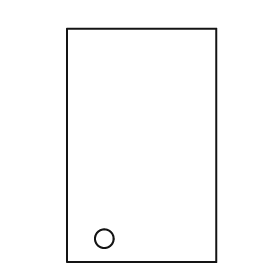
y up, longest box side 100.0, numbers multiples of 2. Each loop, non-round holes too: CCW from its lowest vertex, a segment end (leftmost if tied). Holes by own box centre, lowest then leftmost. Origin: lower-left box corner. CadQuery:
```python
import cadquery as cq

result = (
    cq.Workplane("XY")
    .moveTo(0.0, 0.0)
    .lineTo(64.0, 0.0)
    .lineTo(64.0, 100.0)
    .lineTo(0.0, 100.0)
    .close()
    .moveTo(16.0, 10.0)
    .circle(4.0)
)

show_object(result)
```